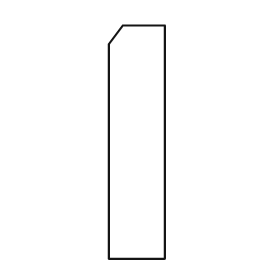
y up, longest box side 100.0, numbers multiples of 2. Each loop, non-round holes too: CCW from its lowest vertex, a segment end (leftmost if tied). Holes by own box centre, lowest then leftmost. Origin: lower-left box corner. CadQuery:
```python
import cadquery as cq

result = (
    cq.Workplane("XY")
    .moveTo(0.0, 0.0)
    .lineTo(24.0, 0.0)
    .lineTo(24.0, 100.0)
    .lineTo(6.0, 100.0)
    .lineTo(0.0, 92.0)
    .close()
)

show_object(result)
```